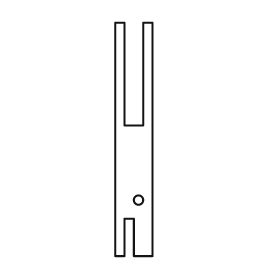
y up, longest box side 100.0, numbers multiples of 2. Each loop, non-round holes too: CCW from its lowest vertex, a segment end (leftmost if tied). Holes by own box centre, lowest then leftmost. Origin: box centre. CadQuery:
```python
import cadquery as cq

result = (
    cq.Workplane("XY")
    .moveTo(-8.0, -50.0)
    .lineTo(-4.0, -50.0)
    .lineTo(-4.0, -34.0)
    .lineTo(0.0, -34.0)
    .lineTo(0.0, -50.0)
    .lineTo(8.0, -50.0)
    .lineTo(8.0, 50.0)
    .lineTo(4.0, 50.0)
    .lineTo(4.0, 6.0)
    .lineTo(-4.0, 6.0)
    .lineTo(-4.0, 50.0)
    .lineTo(-8.0, 50.0)
    .close()
    .moveTo(2.0, -26.0)
    .circle(2.0)
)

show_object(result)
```